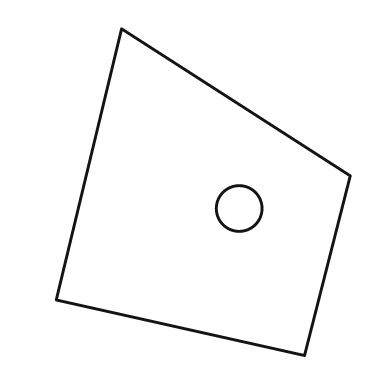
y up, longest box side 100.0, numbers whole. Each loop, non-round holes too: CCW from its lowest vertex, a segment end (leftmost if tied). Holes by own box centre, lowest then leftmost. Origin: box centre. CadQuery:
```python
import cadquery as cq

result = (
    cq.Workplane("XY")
    .moveTo(31.0, -50.0)
    .lineTo(45.0, 5.0)
    .lineTo(-25.0, 50.0)
    .lineTo(-45.0, -33.0)
    .close()
    .moveTo(11.0, -5.0)
    .circle(7.0)
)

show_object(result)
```